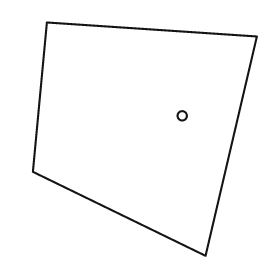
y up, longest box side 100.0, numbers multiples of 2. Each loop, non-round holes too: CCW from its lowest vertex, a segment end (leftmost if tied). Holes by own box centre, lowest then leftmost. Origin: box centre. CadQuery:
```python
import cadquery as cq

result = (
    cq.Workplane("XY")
    .moveTo(26.0, -50.0)
    .lineTo(48.0, 44.0)
    .lineTo(-42.0, 50.0)
    .lineTo(-48.0, -14.0)
    .close()
    .moveTo(16.0, 10.0)
    .circle(2.0)
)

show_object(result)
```